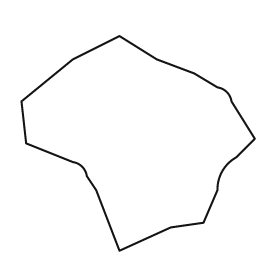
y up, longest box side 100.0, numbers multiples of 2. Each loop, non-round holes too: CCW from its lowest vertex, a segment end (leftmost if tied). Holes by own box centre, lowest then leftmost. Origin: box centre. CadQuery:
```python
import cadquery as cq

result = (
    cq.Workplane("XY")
    .moveTo(-8.0, -46.0)
    .lineTo(14.0, -36.0)
    .lineTo(28.0, -34.0)
    .lineTo(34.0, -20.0)
    .threePointArc((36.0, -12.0), (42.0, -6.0))
    .lineTo(50.0, 2.0)
    .lineTo(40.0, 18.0)
    .threePointArc((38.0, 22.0), (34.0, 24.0))
    .lineTo(24.0, 30.0)
    .lineTo(8.0, 36.0)
    .lineTo(-8.0, 46.0)
    .lineTo(-28.0, 36.0)
    .lineTo(-50.0, 18.0)
    .lineTo(-48.0, 0.0)
    .lineTo(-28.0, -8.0)
    .threePointArc((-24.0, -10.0), (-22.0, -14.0))
    .lineTo(-18.0, -20.0)
    .close()
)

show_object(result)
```